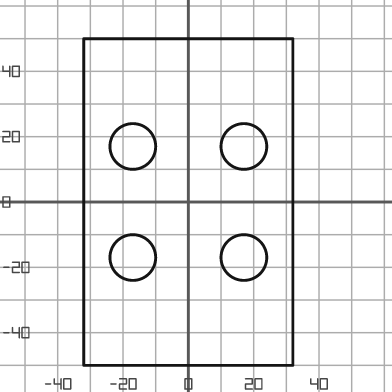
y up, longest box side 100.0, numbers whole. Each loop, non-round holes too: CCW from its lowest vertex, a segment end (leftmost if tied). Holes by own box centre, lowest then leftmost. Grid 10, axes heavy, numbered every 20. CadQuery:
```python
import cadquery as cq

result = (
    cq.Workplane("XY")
    .moveTo(-32.0, -50.0)
    .lineTo(32.0, -50.0)
    .lineTo(32.0, 50.0)
    .lineTo(-32.0, 50.0)
    .close()
    .moveTo(-17.0, -17.0)
    .circle(7.0)
    .moveTo(17.0, -17.0)
    .circle(7.0)
    .moveTo(-17.0, 17.0)
    .circle(7.0)
    .moveTo(17.0, 17.0)
    .circle(7.0)
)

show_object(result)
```